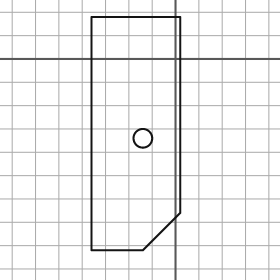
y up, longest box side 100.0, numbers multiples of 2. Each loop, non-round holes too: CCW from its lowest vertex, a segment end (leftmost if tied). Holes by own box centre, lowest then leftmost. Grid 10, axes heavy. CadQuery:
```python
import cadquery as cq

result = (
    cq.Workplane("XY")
    .moveTo(-36.0, -82.0)
    .lineTo(-14.0, -82.0)
    .lineTo(2.0, -66.0)
    .lineTo(2.0, 18.0)
    .lineTo(-36.0, 18.0)
    .close()
    .moveTo(-14.0, -34.0)
    .circle(4.0)
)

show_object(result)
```